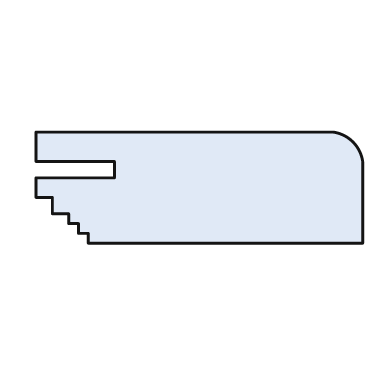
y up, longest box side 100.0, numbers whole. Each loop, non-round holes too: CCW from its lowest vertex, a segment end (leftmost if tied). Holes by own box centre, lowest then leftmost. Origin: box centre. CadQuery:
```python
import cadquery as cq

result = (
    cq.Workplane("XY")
    .moveTo(-34.0, -17.0)
    .lineTo(50.0, -17.0)
    .lineTo(50.0, 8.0)
    .threePointArc((47.0, 14.0), (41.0, 17.0))
    .lineTo(-50.0, 17.0)
    .lineTo(-50.0, 8.0)
    .lineTo(-26.0, 8.0)
    .lineTo(-26.0, 3.0)
    .lineTo(-50.0, 3.0)
    .lineTo(-50.0, -3.0)
    .lineTo(-45.0, -3.0)
    .lineTo(-45.0, -8.0)
    .lineTo(-40.0, -8.0)
    .lineTo(-40.0, -11.0)
    .lineTo(-37.0, -11.0)
    .lineTo(-37.0, -14.0)
    .lineTo(-34.0, -14.0)
    .close()
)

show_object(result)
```